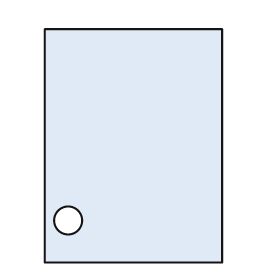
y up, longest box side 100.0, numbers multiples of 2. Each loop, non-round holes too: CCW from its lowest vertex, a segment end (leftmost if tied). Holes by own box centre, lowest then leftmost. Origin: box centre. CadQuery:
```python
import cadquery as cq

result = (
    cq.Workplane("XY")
    .moveTo(-38.0, -50.0)
    .lineTo(38.0, -50.0)
    .lineTo(38.0, 50.0)
    .lineTo(-38.0, 50.0)
    .close()
    .moveTo(-28.0, -32.0)
    .circle(6.0)
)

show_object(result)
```